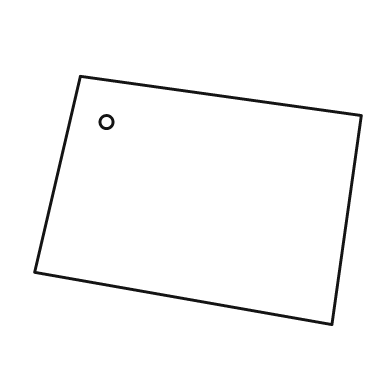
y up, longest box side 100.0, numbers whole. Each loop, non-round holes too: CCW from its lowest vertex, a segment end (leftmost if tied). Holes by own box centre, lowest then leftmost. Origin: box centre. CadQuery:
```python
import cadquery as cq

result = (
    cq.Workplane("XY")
    .moveTo(41.0, -38.0)
    .lineTo(50.0, 26.0)
    .lineTo(-36.0, 38.0)
    .lineTo(-50.0, -22.0)
    .close()
    .moveTo(-28.0, 24.0)
    .circle(2.0)
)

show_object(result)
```